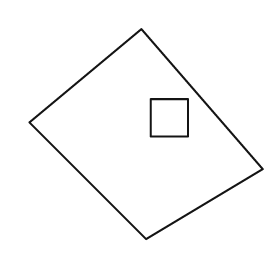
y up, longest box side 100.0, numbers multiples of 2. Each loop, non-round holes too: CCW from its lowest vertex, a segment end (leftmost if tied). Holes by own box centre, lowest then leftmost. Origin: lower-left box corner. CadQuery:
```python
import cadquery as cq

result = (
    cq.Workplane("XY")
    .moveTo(50.0, 0.0)
    .lineTo(100.0, 30.0)
    .lineTo(48.0, 90.0)
    .lineTo(0.0, 50.0)
    .close()
    .moveTo(52.0, 44.0)
    .lineTo(68.0, 44.0)
    .lineTo(68.0, 60.0)
    .lineTo(52.0, 60.0)
    .close()
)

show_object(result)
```